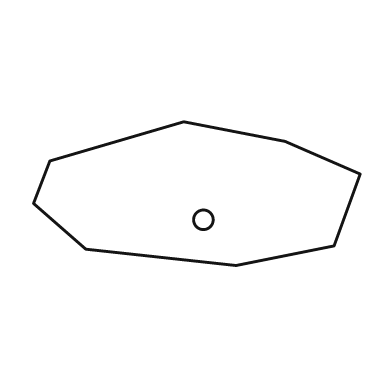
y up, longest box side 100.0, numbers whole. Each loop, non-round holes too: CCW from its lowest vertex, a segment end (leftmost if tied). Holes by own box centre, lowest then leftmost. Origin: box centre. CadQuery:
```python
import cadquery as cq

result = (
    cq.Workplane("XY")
    .moveTo(12.0, -22.0)
    .lineTo(42.0, -16.0)
    .lineTo(50.0, 6.0)
    .lineTo(27.0, 16.0)
    .lineTo(-4.0, 22.0)
    .lineTo(-45.0, 10.0)
    .lineTo(-50.0, -3.0)
    .lineTo(-34.0, -17.0)
    .close()
    .moveTo(2.0, -8.0)
    .circle(3.0)
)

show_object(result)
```